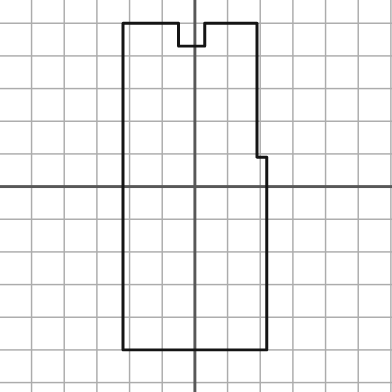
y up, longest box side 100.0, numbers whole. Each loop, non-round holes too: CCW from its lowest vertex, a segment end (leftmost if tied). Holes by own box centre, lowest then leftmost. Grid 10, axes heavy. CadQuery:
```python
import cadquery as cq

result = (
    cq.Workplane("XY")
    .moveTo(-22.0, -50.0)
    .lineTo(22.0, -50.0)
    .lineTo(22.0, 9.0)
    .lineTo(19.0, 9.0)
    .lineTo(19.0, 50.0)
    .lineTo(3.0, 50.0)
    .lineTo(3.0, 43.0)
    .lineTo(-5.0, 43.0)
    .lineTo(-5.0, 50.0)
    .lineTo(-22.0, 50.0)
    .close()
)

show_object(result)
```